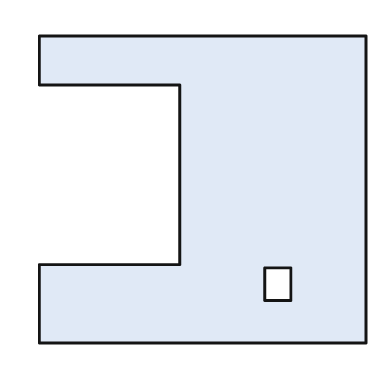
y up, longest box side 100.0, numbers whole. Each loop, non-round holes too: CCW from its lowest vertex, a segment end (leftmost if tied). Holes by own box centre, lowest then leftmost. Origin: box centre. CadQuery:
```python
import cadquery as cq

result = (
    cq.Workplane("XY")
    .moveTo(-50.0, -47.0)
    .lineTo(50.0, -47.0)
    .lineTo(50.0, 47.0)
    .lineTo(-50.0, 47.0)
    .lineTo(-50.0, 32.0)
    .lineTo(-7.0, 32.0)
    .lineTo(-7.0, -23.0)
    .lineTo(-50.0, -23.0)
    .close()
    .moveTo(19.0, -34.0)
    .lineTo(27.0, -34.0)
    .lineTo(27.0, -24.0)
    .lineTo(19.0, -24.0)
    .close()
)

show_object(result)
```